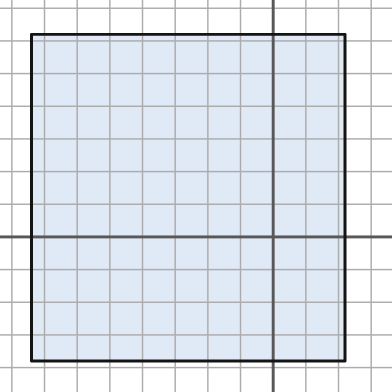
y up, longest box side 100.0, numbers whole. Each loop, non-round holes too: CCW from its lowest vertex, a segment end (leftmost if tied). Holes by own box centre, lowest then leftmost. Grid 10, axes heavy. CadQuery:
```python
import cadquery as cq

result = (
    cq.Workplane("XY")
    .moveTo(-74.0, -38.0)
    .lineTo(22.0, -38.0)
    .lineTo(22.0, 62.0)
    .lineTo(-74.0, 62.0)
    .close()
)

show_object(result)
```